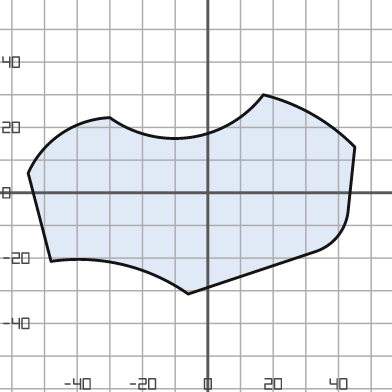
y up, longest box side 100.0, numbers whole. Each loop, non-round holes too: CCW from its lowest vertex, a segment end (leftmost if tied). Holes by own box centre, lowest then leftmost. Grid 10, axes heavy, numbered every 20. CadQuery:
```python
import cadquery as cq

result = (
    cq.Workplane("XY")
    .moveTo(-6.0, -31.0)
    .lineTo(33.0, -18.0)
    .threePointArc((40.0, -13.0), (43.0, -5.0))
    .lineTo(45.0, 14.0)
    .threePointArc((32.0, 24.0), (17.0, 30.0))
    .threePointArc((-5.0, 17.0), (-30.0, 23.0))
    .threePointArc((-45.0, 18.0), (-55.0, 6.0))
    .lineTo(-48.0, -21.0)
    .threePointArc((-26.0, -22.0), (-6.0, -31.0))
    .close()
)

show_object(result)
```